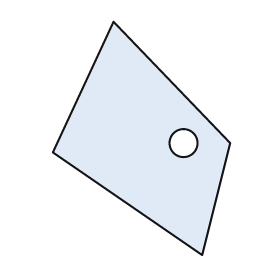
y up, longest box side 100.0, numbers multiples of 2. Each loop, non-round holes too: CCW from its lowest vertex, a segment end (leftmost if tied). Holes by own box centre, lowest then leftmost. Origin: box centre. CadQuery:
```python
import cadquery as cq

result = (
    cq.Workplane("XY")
    .moveTo(26.0, -50.0)
    .lineTo(38.0, -2.0)
    .lineTo(-12.0, 50.0)
    .lineTo(-38.0, -6.0)
    .close()
    .moveTo(18.0, -2.0)
    .circle(6.0)
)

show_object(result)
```